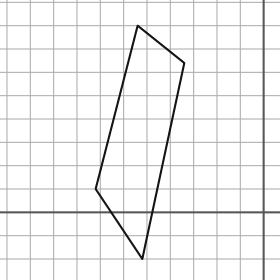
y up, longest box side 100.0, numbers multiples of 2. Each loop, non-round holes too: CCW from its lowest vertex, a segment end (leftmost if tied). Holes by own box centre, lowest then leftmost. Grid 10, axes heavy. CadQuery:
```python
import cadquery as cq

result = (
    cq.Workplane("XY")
    .moveTo(-52.0, -20.0)
    .lineTo(-34.0, 64.0)
    .lineTo(-54.0, 80.0)
    .lineTo(-72.0, 10.0)
    .close()
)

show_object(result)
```